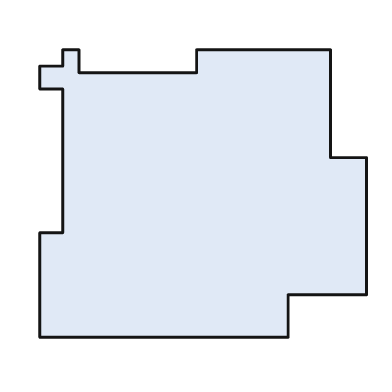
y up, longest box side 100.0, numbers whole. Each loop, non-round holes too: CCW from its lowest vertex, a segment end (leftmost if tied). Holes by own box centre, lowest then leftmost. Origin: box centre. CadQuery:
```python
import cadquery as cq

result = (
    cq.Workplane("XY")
    .moveTo(-50.0, -44.0)
    .lineTo(26.0, -44.0)
    .lineTo(26.0, -31.0)
    .lineTo(50.0, -31.0)
    .lineTo(50.0, 11.0)
    .lineTo(39.0, 11.0)
    .lineTo(39.0, 44.0)
    .lineTo(-2.0, 44.0)
    .lineTo(-2.0, 37.0)
    .lineTo(-38.0, 37.0)
    .lineTo(-38.0, 44.0)
    .lineTo(-43.0, 44.0)
    .lineTo(-43.0, 39.0)
    .lineTo(-50.0, 39.0)
    .lineTo(-50.0, 32.0)
    .lineTo(-43.0, 32.0)
    .lineTo(-43.0, -12.0)
    .lineTo(-50.0, -12.0)
    .close()
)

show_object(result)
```